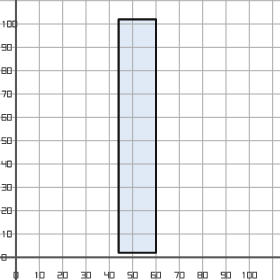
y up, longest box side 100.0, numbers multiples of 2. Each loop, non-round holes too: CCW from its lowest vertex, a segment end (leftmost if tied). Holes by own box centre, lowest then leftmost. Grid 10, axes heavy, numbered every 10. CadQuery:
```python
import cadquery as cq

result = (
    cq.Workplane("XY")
    .moveTo(44.0, 2.0)
    .lineTo(60.0, 2.0)
    .lineTo(60.0, 102.0)
    .lineTo(44.0, 102.0)
    .close()
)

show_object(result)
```